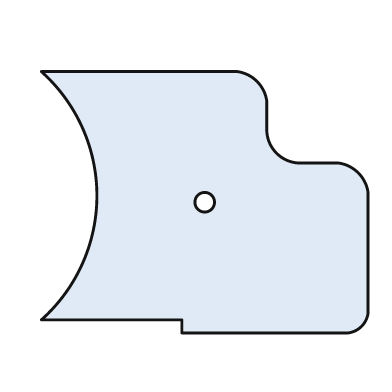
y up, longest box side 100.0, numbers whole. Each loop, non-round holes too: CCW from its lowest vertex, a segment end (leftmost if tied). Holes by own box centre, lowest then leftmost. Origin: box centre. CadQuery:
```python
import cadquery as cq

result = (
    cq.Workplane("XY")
    .moveTo(-7.0, -40.0)
    .lineTo(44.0, -40.0)
    .threePointArc((48.0, -38.0), (50.0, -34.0))
    .lineTo(50.0, 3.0)
    .threePointArc((47.0, 9.0), (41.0, 12.0))
    .lineTo(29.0, 12.0)
    .threePointArc((22.0, 15.0), (19.0, 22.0))
    .lineTo(19.0, 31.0)
    .threePointArc((16.0, 37.0), (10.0, 40.0))
    .lineTo(-50.0, 40.0)
    .threePointArc((-33.0, 2.0), (-50.0, -36.0))
    .lineTo(-7.0, -36.0)
    .close()
    .moveTo(0.0, 0.0)
    .circle(3.0)
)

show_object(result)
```